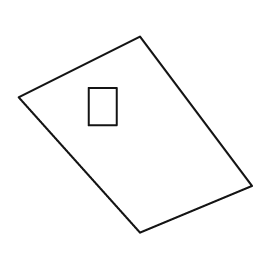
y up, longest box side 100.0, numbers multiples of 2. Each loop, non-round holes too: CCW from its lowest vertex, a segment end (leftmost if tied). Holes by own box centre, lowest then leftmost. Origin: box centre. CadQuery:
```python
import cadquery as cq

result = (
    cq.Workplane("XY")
    .moveTo(2.0, -42.0)
    .lineTo(50.0, -22.0)
    .lineTo(2.0, 42.0)
    .lineTo(-50.0, 16.0)
    .close()
    .moveTo(-20.0, 4.0)
    .lineTo(-8.0, 4.0)
    .lineTo(-8.0, 20.0)
    .lineTo(-20.0, 20.0)
    .close()
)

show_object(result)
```